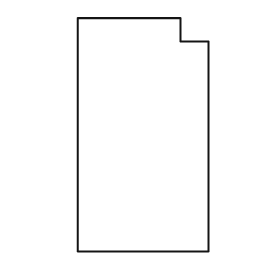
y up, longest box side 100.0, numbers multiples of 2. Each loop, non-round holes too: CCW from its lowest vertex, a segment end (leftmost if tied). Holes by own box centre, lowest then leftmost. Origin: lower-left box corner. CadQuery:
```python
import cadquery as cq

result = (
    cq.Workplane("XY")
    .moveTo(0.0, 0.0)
    .lineTo(56.0, 0.0)
    .lineTo(56.0, 90.0)
    .lineTo(44.0, 90.0)
    .lineTo(44.0, 100.0)
    .lineTo(0.0, 100.0)
    .close()
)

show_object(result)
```